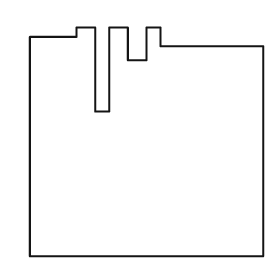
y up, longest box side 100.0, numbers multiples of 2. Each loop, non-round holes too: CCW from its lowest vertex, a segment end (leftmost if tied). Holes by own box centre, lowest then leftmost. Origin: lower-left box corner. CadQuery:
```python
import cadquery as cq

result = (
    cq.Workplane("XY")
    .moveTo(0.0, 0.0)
    .lineTo(100.0, 0.0)
    .lineTo(100.0, 90.0)
    .lineTo(56.0, 90.0)
    .lineTo(56.0, 98.0)
    .lineTo(50.0, 98.0)
    .lineTo(50.0, 84.0)
    .lineTo(42.0, 84.0)
    .lineTo(42.0, 98.0)
    .lineTo(34.0, 98.0)
    .lineTo(34.0, 62.0)
    .lineTo(28.0, 62.0)
    .lineTo(28.0, 98.0)
    .lineTo(20.0, 98.0)
    .lineTo(20.0, 94.0)
    .lineTo(0.0, 94.0)
    .close()
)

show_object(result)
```